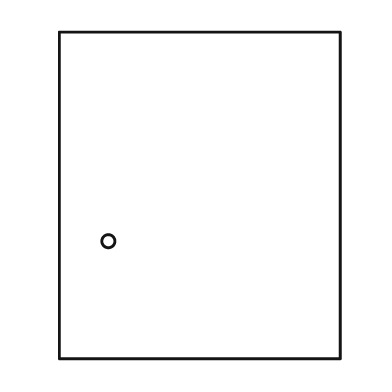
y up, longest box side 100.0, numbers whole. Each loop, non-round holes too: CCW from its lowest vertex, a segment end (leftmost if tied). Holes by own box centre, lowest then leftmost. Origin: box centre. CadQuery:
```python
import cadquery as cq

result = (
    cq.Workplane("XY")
    .moveTo(-43.0, -50.0)
    .lineTo(43.0, -50.0)
    .lineTo(43.0, 50.0)
    .lineTo(-43.0, 50.0)
    .close()
    .moveTo(-28.0, -14.0)
    .circle(2.0)
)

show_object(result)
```